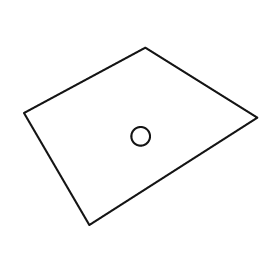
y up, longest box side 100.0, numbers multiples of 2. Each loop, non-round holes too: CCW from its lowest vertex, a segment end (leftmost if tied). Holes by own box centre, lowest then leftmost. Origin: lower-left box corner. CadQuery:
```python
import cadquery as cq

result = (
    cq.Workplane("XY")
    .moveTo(28.0, 0.0)
    .lineTo(100.0, 46.0)
    .lineTo(52.0, 76.0)
    .lineTo(0.0, 48.0)
    .close()
    .moveTo(50.0, 38.0)
    .circle(4.0)
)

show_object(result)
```